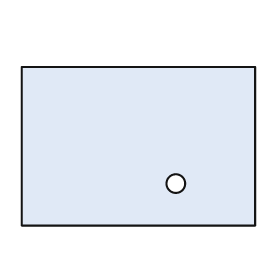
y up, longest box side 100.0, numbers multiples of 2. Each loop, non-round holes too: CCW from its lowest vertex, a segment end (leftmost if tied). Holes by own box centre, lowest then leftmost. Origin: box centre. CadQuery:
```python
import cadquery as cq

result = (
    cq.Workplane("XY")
    .moveTo(-50.0, -34.0)
    .lineTo(50.0, -34.0)
    .lineTo(50.0, 34.0)
    .lineTo(-50.0, 34.0)
    .close()
    .moveTo(16.0, -16.0)
    .circle(4.0)
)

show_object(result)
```